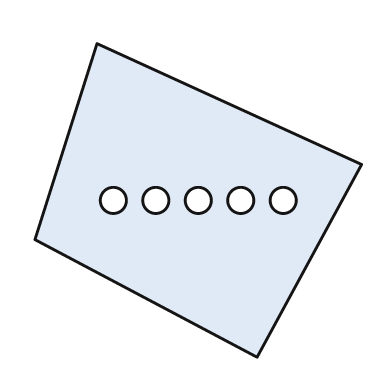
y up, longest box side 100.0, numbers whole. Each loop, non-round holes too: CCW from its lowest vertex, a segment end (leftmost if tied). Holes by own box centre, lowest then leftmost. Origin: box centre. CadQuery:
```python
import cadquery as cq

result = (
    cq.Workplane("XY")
    .moveTo(18.0, -48.0)
    .lineTo(50.0, 11.0)
    .lineTo(-31.0, 48.0)
    .lineTo(-50.0, -12.0)
    .close()
    .moveTo(-26.0, 0.0)
    .circle(4.0)
    .moveTo(-13.0, 0.0)
    .circle(4.0)
    .moveTo(0.0, 0.0)
    .circle(4.0)
    .moveTo(13.0, 0.0)
    .circle(4.0)
    .moveTo(26.0, 0.0)
    .circle(4.0)
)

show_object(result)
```